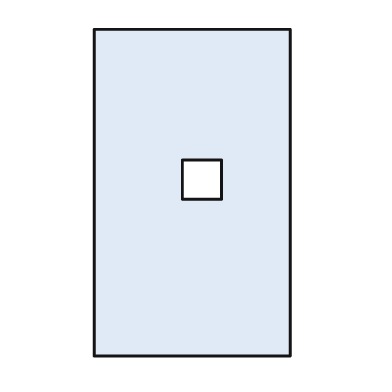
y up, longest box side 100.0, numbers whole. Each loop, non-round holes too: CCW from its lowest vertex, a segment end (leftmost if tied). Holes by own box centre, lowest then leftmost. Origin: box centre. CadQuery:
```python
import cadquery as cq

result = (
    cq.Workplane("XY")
    .moveTo(-30.0, -50.0)
    .lineTo(30.0, -50.0)
    .lineTo(30.0, 50.0)
    .lineTo(-30.0, 50.0)
    .close()
    .moveTo(-3.0, -2.0)
    .lineTo(9.0, -2.0)
    .lineTo(9.0, 10.0)
    .lineTo(-3.0, 10.0)
    .close()
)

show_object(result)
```